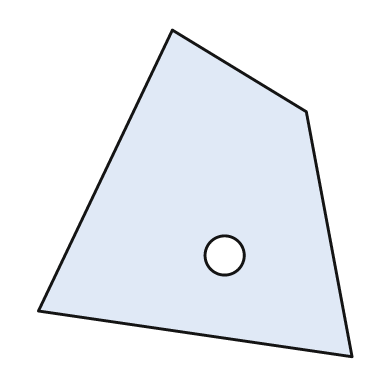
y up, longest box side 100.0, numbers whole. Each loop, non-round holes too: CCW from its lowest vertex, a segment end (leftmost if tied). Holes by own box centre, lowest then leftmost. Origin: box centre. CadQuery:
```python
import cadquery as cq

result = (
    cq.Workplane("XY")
    .moveTo(48.0, -50.0)
    .lineTo(34.0, 25.0)
    .lineTo(-7.0, 50.0)
    .lineTo(-48.0, -36.0)
    .close()
    .moveTo(9.0, -19.0)
    .circle(6.0)
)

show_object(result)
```